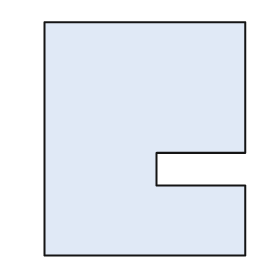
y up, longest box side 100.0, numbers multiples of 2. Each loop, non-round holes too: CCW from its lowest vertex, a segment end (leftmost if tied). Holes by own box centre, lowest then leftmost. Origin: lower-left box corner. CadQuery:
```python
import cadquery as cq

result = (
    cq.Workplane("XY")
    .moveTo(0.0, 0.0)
    .lineTo(86.0, 0.0)
    .lineTo(86.0, 30.0)
    .lineTo(48.0, 30.0)
    .lineTo(48.0, 44.0)
    .lineTo(86.0, 44.0)
    .lineTo(86.0, 100.0)
    .lineTo(0.0, 100.0)
    .close()
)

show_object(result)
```